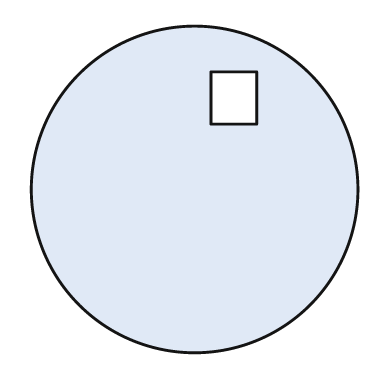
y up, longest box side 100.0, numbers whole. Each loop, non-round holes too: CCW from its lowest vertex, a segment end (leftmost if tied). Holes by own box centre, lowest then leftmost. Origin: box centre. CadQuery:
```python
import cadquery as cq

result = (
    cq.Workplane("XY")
    .moveTo(0.0, 0.0)
    .circle(50.0)
    .moveTo(5.0, 20.0)
    .lineTo(19.0, 20.0)
    .lineTo(19.0, 36.0)
    .lineTo(5.0, 36.0)
    .close()
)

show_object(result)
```